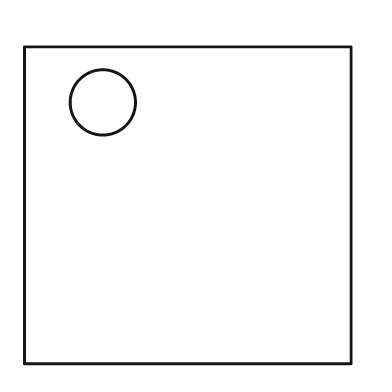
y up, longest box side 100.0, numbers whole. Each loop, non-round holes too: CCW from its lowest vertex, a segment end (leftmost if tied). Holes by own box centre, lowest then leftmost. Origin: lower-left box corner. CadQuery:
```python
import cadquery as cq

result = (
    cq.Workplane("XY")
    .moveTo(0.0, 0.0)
    .lineTo(100.0, 0.0)
    .lineTo(100.0, 97.0)
    .lineTo(0.0, 97.0)
    .close()
    .moveTo(24.0, 80.0)
    .circle(10.0)
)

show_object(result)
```